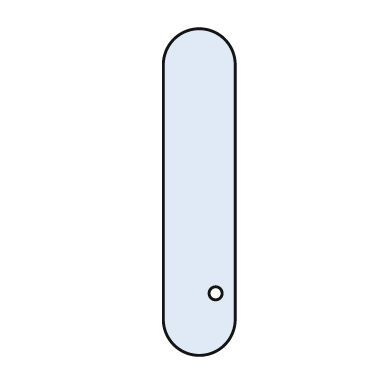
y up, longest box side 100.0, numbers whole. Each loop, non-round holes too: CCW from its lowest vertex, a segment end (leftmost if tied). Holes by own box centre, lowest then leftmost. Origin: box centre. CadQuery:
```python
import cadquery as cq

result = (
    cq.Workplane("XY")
    .moveTo(-11.0, -39.0)
    .threePointArc((0.0, -50.0), (11.0, -39.0))
    .lineTo(11.0, 39.0)
    .threePointArc((0.0, 50.0), (-11.0, 39.0))
    .close()
    .moveTo(5.0, -31.0)
    .circle(2.0)
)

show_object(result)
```